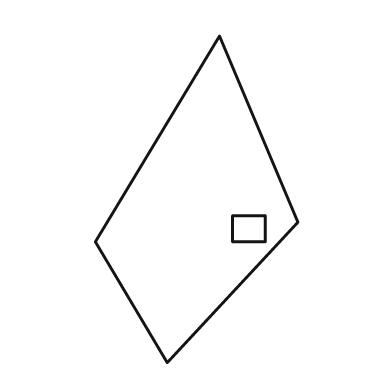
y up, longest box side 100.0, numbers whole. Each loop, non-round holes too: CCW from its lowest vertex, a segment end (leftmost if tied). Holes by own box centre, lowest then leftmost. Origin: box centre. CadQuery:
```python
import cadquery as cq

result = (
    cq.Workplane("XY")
    .moveTo(-9.0, -50.0)
    .lineTo(31.0, -7.0)
    .lineTo(7.0, 50.0)
    .lineTo(-31.0, -13.0)
    .close()
    .moveTo(11.0, -13.0)
    .lineTo(21.0, -13.0)
    .lineTo(21.0, -5.0)
    .lineTo(11.0, -5.0)
    .close()
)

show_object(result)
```